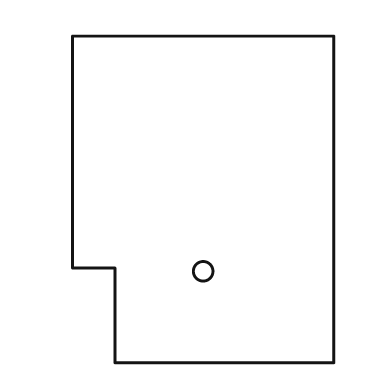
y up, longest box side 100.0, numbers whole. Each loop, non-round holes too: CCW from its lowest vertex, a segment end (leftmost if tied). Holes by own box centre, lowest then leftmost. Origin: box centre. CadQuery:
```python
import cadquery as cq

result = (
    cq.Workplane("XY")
    .moveTo(-27.0, -50.0)
    .lineTo(40.0, -50.0)
    .lineTo(40.0, 50.0)
    .lineTo(-40.0, 50.0)
    .lineTo(-40.0, -21.0)
    .lineTo(-27.0, -21.0)
    .close()
    .moveTo(0.0, -22.0)
    .circle(3.0)
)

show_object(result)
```